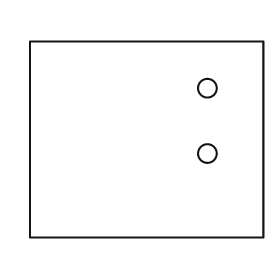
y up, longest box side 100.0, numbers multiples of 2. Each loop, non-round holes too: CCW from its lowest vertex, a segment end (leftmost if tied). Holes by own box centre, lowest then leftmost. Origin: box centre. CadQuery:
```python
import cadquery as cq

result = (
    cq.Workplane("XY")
    .moveTo(-50.0, -42.0)
    .lineTo(50.0, -42.0)
    .lineTo(50.0, 42.0)
    .lineTo(-50.0, 42.0)
    .close()
    .moveTo(26.0, -6.0)
    .circle(4.0)
    .moveTo(26.0, 22.0)
    .circle(4.0)
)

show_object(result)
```